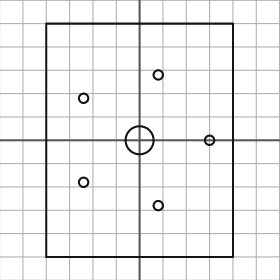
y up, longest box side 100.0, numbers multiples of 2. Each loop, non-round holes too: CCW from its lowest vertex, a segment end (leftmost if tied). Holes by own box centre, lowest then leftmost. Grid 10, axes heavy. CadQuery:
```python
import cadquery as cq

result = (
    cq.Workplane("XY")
    .moveTo(-40.0, -50.0)
    .lineTo(40.0, -50.0)
    .lineTo(40.0, 50.0)
    .lineTo(-40.0, 50.0)
    .close()
    .moveTo(8.0, -28.0)
    .circle(2.0)
    .moveTo(-24.0, -18.0)
    .circle(2.0)
    .moveTo(0.0, 0.0)
    .circle(6.0)
    .moveTo(30.0, 0.0)
    .circle(2.0)
    .moveTo(-24.0, 18.0)
    .circle(2.0)
    .moveTo(8.0, 28.0)
    .circle(2.0)
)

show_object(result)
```